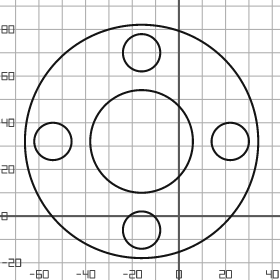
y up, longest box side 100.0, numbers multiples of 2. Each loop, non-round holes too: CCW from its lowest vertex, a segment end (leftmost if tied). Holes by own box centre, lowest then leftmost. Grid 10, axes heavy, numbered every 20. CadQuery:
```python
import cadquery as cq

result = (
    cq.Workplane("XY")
    .moveTo(-16.0, 32.0)
    .circle(50.0)
    .moveTo(-16.0, -6.0)
    .circle(8.0)
    .moveTo(-54.0, 32.0)
    .circle(8.0)
    .moveTo(-16.0, 32.0)
    .circle(22.0)
    .moveTo(22.0, 32.0)
    .circle(8.0)
    .moveTo(-16.0, 70.0)
    .circle(8.0)
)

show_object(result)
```